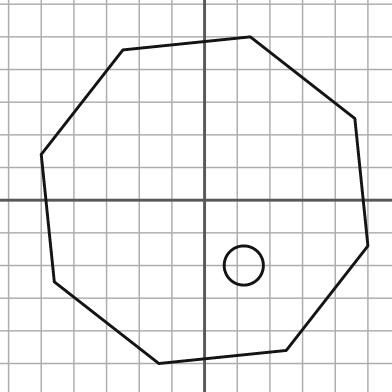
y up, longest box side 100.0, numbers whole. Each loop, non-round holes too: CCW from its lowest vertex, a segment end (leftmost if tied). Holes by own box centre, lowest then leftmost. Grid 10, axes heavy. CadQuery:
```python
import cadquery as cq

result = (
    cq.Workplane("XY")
    .moveTo(-14.0, -50.0)
    .lineTo(25.0, -46.0)
    .lineTo(50.0, -14.0)
    .lineTo(46.0, 25.0)
    .lineTo(14.0, 50.0)
    .lineTo(-25.0, 46.0)
    .lineTo(-50.0, 14.0)
    .lineTo(-46.0, -25.0)
    .close()
    .moveTo(12.0, -20.0)
    .circle(6.0)
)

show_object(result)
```